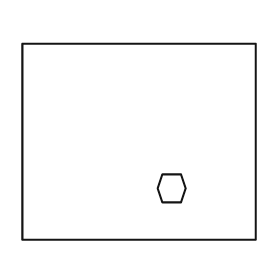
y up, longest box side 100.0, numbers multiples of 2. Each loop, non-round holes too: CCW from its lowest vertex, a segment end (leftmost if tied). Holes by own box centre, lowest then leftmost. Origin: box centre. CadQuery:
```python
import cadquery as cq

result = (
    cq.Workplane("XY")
    .moveTo(-50.0, -42.0)
    .lineTo(50.0, -42.0)
    .lineTo(50.0, 42.0)
    .lineTo(-50.0, 42.0)
    .close()
    .moveTo(10.0, -26.0)
    .lineTo(18.0, -26.0)
    .lineTo(20.0, -20.0)
    .lineTo(18.0, -14.0)
    .lineTo(10.0, -14.0)
    .lineTo(8.0, -20.0)
    .close()
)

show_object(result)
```